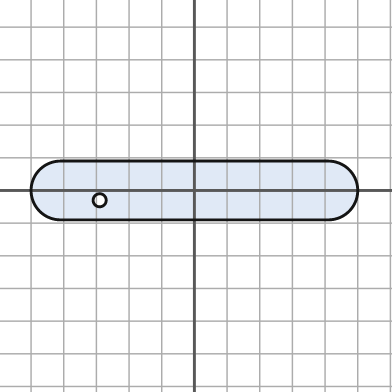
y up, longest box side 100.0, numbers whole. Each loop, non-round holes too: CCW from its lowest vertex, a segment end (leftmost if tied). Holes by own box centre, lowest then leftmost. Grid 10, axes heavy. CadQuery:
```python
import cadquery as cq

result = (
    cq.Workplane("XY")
    .moveTo(-41.0, -9.0)
    .lineTo(41.0, -9.0)
    .threePointArc((50.0, 0.0), (41.0, 9.0))
    .lineTo(-41.0, 9.0)
    .threePointArc((-50.0, 0.0), (-41.0, -9.0))
    .close()
    .moveTo(-29.0, -3.0)
    .circle(2.0)
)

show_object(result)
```